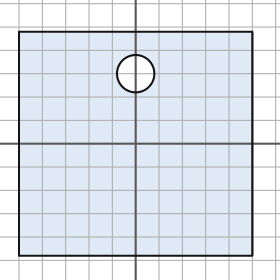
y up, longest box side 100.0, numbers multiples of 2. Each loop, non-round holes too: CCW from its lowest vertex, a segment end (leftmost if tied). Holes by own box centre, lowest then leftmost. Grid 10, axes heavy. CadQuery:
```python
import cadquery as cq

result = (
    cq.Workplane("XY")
    .moveTo(-50.0, -48.0)
    .lineTo(50.0, -48.0)
    .lineTo(50.0, 48.0)
    .lineTo(-50.0, 48.0)
    .close()
    .moveTo(0.0, 30.0)
    .circle(8.0)
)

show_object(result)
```